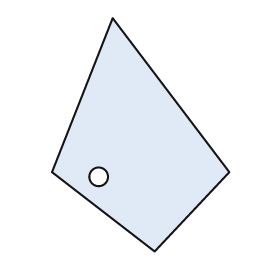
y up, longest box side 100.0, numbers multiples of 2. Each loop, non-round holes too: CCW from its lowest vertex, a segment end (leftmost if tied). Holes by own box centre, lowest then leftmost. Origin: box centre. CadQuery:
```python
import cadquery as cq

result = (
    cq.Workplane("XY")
    .moveTo(6.0, -50.0)
    .lineTo(38.0, -16.0)
    .lineTo(-12.0, 50.0)
    .lineTo(-38.0, -16.0)
    .close()
    .moveTo(-18.0, -18.0)
    .circle(4.0)
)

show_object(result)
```